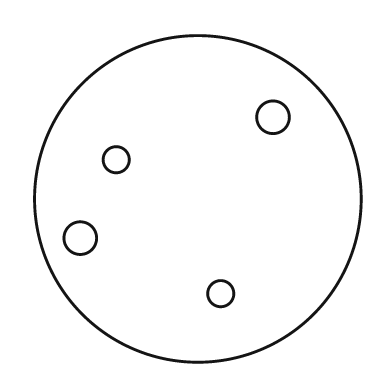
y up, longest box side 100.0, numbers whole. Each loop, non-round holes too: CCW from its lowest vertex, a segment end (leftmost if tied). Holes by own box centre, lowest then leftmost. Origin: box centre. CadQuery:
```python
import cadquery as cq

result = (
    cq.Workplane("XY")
    .moveTo(0.0, 0.0)
    .circle(50.0)
    .moveTo(7.0, -29.0)
    .circle(4.0)
    .moveTo(-36.0, -12.0)
    .circle(5.0)
    .moveTo(-25.0, 12.0)
    .circle(4.0)
    .moveTo(23.0, 25.0)
    .circle(5.0)
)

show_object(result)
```